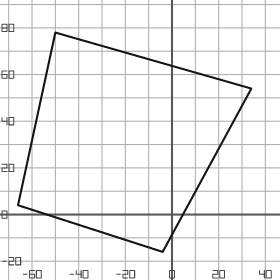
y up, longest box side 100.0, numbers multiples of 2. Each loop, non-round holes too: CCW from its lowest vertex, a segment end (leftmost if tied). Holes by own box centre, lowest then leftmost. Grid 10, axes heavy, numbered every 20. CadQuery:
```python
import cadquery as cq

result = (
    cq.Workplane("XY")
    .moveTo(-4.0, -16.0)
    .lineTo(34.0, 54.0)
    .lineTo(-50.0, 78.0)
    .lineTo(-66.0, 4.0)
    .close()
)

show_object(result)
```